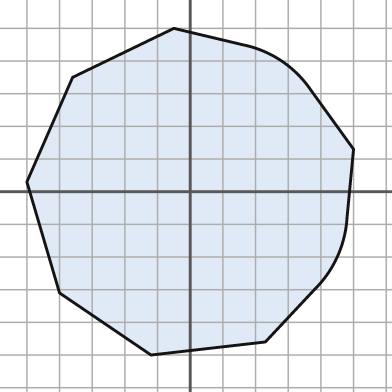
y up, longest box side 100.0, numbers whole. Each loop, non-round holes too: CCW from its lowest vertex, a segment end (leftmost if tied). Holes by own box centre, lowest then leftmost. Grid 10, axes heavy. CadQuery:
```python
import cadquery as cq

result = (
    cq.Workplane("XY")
    .moveTo(-12.0, -50.0)
    .lineTo(23.0, -46.0)
    .lineTo(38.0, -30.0)
    .threePointArc((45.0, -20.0), (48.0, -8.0))
    .lineTo(50.0, 13.0)
    .lineTo(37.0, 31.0)
    .threePointArc((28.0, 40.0), (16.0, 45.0))
    .lineTo(-5.0, 50.0)
    .lineTo(-36.0, 35.0)
    .lineTo(-50.0, 3.0)
    .lineTo(-40.0, -31.0)
    .close()
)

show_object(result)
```